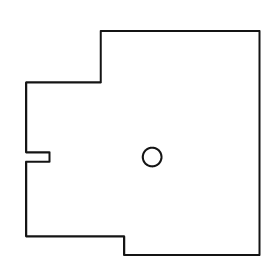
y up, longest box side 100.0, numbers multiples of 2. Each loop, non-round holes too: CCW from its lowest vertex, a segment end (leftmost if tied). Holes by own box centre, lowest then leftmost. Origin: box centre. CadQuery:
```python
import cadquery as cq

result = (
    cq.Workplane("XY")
    .moveTo(-8.0, -48.0)
    .lineTo(50.0, -48.0)
    .lineTo(50.0, 48.0)
    .lineTo(-18.0, 48.0)
    .lineTo(-18.0, 26.0)
    .lineTo(-50.0, 26.0)
    .lineTo(-50.0, -4.0)
    .lineTo(-40.0, -4.0)
    .lineTo(-40.0, -8.0)
    .lineTo(-50.0, -8.0)
    .lineTo(-50.0, -40.0)
    .lineTo(-8.0, -40.0)
    .close()
    .moveTo(4.0, -6.0)
    .circle(4.0)
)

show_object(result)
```